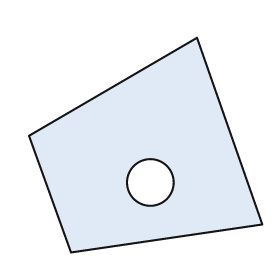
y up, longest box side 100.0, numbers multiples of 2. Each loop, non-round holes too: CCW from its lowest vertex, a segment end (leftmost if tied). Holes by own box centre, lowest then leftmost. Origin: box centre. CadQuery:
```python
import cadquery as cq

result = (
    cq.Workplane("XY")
    .moveTo(-32.0, -46.0)
    .lineTo(50.0, -34.0)
    .lineTo(22.0, 46.0)
    .lineTo(-50.0, 4.0)
    .close()
    .moveTo(2.0, -16.0)
    .circle(10.0)
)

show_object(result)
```